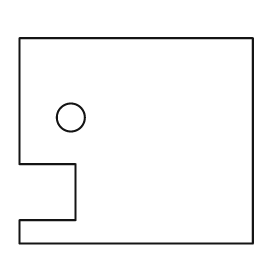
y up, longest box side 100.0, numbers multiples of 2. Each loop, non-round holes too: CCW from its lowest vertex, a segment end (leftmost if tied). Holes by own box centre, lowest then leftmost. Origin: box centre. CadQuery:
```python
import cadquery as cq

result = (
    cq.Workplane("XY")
    .moveTo(-50.0, -44.0)
    .lineTo(50.0, -44.0)
    .lineTo(50.0, 44.0)
    .lineTo(-50.0, 44.0)
    .lineTo(-50.0, -10.0)
    .lineTo(-26.0, -10.0)
    .lineTo(-26.0, -34.0)
    .lineTo(-50.0, -34.0)
    .close()
    .moveTo(-28.0, 10.0)
    .circle(6.0)
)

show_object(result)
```